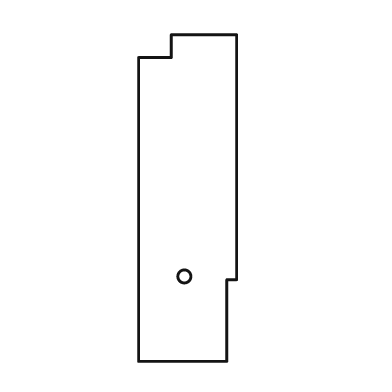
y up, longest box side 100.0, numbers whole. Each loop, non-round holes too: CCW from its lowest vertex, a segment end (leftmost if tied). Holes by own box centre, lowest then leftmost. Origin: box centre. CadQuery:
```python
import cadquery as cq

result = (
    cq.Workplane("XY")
    .moveTo(-15.0, -50.0)
    .lineTo(12.0, -50.0)
    .lineTo(12.0, -25.0)
    .lineTo(15.0, -25.0)
    .lineTo(15.0, 50.0)
    .lineTo(-5.0, 50.0)
    .lineTo(-5.0, 43.0)
    .lineTo(-15.0, 43.0)
    .close()
    .moveTo(-1.0, -24.0)
    .circle(2.0)
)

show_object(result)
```